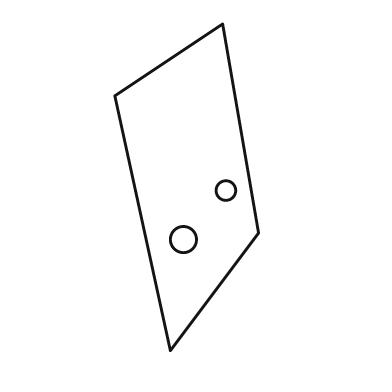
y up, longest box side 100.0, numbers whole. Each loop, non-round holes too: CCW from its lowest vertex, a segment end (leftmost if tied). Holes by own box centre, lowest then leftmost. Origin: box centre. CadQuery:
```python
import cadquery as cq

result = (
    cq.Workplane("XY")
    .moveTo(-5.0, -50.0)
    .lineTo(22.0, -14.0)
    .lineTo(11.0, 50.0)
    .lineTo(-22.0, 28.0)
    .close()
    .moveTo(-1.0, -16.0)
    .circle(4.0)
    .moveTo(12.0, -1.0)
    .circle(3.0)
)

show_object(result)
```